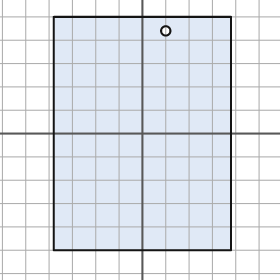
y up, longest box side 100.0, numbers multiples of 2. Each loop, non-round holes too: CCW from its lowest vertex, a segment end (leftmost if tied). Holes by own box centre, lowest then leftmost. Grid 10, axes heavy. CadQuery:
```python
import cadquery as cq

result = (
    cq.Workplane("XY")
    .moveTo(-38.0, -50.0)
    .lineTo(38.0, -50.0)
    .lineTo(38.0, 50.0)
    .lineTo(-38.0, 50.0)
    .close()
    .moveTo(10.0, 44.0)
    .circle(2.0)
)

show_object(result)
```